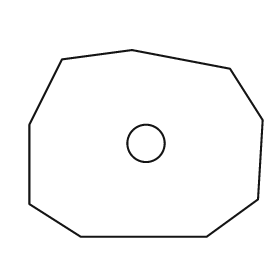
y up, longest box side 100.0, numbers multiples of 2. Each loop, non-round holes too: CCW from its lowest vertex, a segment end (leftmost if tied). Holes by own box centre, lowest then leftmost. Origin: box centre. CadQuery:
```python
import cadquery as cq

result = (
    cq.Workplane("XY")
    .moveTo(-28.0, -40.0)
    .lineTo(26.0, -40.0)
    .lineTo(48.0, -24.0)
    .lineTo(50.0, 10.0)
    .lineTo(36.0, 32.0)
    .lineTo(-6.0, 40.0)
    .lineTo(-36.0, 36.0)
    .lineTo(-50.0, 8.0)
    .lineTo(-50.0, -26.0)
    .close()
    .moveTo(0.0, 0.0)
    .circle(8.0)
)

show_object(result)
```